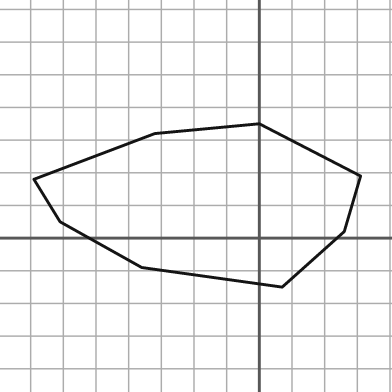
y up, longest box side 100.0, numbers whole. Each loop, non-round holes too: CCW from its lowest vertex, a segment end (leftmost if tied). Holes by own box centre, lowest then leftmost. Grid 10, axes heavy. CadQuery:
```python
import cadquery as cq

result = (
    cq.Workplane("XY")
    .moveTo(7.0, -15.0)
    .lineTo(26.0, 2.0)
    .lineTo(31.0, 19.0)
    .lineTo(0.0, 35.0)
    .lineTo(-32.0, 32.0)
    .lineTo(-69.0, 18.0)
    .lineTo(-61.0, 5.0)
    .lineTo(-36.0, -9.0)
    .close()
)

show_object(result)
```